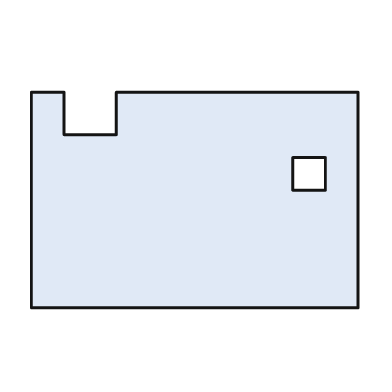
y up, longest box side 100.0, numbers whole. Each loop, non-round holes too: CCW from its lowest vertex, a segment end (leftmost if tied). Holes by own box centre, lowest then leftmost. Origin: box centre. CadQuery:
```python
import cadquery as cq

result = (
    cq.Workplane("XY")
    .moveTo(-50.0, -33.0)
    .lineTo(50.0, -33.0)
    .lineTo(50.0, 33.0)
    .lineTo(-24.0, 33.0)
    .lineTo(-24.0, 20.0)
    .lineTo(-40.0, 20.0)
    .lineTo(-40.0, 33.0)
    .lineTo(-50.0, 33.0)
    .close()
    .moveTo(30.0, 3.0)
    .lineTo(40.0, 3.0)
    .lineTo(40.0, 13.0)
    .lineTo(30.0, 13.0)
    .close()
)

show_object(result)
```